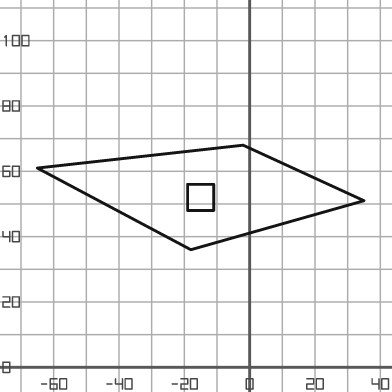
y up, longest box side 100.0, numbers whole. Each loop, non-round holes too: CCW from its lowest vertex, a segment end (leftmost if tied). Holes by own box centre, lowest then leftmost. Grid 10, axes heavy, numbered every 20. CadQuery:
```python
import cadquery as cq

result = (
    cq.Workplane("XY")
    .moveTo(-18.0, 36.0)
    .lineTo(35.0, 51.0)
    .lineTo(-2.0, 68.0)
    .lineTo(-65.0, 61.0)
    .close()
    .moveTo(-19.0, 48.0)
    .lineTo(-11.0, 48.0)
    .lineTo(-11.0, 56.0)
    .lineTo(-19.0, 56.0)
    .close()
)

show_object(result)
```